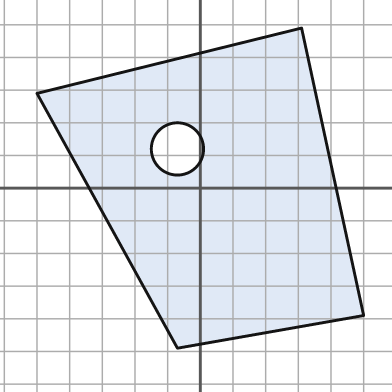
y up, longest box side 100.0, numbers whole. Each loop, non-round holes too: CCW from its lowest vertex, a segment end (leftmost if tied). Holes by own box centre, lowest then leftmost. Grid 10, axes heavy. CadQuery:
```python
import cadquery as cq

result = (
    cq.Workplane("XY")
    .moveTo(-7.0, -49.0)
    .lineTo(50.0, -39.0)
    .lineTo(31.0, 49.0)
    .lineTo(-50.0, 29.0)
    .close()
    .moveTo(-7.0, 12.0)
    .circle(8.0)
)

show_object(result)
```